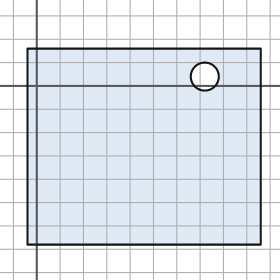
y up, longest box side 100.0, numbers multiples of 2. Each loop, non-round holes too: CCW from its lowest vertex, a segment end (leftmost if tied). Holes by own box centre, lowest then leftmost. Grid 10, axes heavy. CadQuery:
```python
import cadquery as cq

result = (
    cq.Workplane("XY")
    .moveTo(-4.0, -68.0)
    .lineTo(96.0, -68.0)
    .lineTo(96.0, 16.0)
    .lineTo(-4.0, 16.0)
    .close()
    .moveTo(72.0, 4.0)
    .circle(6.0)
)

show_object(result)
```